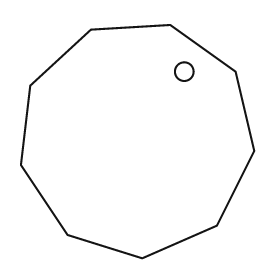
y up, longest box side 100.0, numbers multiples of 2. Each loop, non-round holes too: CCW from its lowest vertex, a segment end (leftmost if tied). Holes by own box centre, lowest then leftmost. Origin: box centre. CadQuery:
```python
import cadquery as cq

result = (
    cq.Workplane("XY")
    .moveTo(2.0, -50.0)
    .lineTo(34.0, -36.0)
    .lineTo(50.0, -4.0)
    .lineTo(42.0, 30.0)
    .lineTo(14.0, 50.0)
    .lineTo(-20.0, 48.0)
    .lineTo(-46.0, 24.0)
    .lineTo(-50.0, -10.0)
    .lineTo(-30.0, -40.0)
    .close()
    .moveTo(20.0, 30.0)
    .circle(4.0)
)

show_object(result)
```